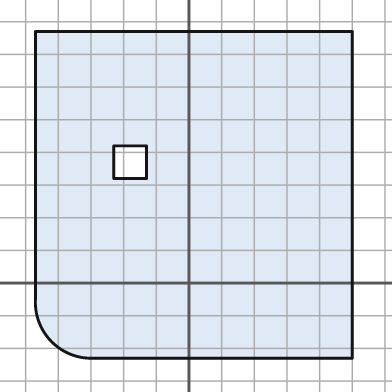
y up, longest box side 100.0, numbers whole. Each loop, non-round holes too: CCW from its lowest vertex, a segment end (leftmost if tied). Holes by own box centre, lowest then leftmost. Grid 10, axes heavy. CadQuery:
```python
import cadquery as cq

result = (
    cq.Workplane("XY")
    .moveTo(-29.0, -23.0)
    .lineTo(50.0, -23.0)
    .lineTo(50.0, 77.0)
    .lineTo(-47.0, 77.0)
    .lineTo(-47.0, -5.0)
    .threePointArc((-42.0, -18.0), (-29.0, -23.0))
    .close()
    .moveTo(-23.0, 32.0)
    .lineTo(-13.0, 32.0)
    .lineTo(-13.0, 42.0)
    .lineTo(-23.0, 42.0)
    .close()
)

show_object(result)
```